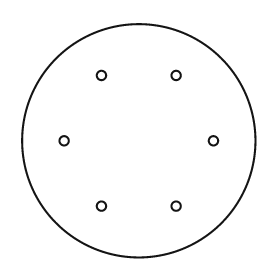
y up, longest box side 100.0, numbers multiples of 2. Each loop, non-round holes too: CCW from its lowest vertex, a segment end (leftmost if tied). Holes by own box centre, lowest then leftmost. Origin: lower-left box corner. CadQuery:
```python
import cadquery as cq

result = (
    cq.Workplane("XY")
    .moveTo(50.0, 50.0)
    .circle(50.0)
    .moveTo(34.0, 22.0)
    .circle(2.0)
    .moveTo(66.0, 22.0)
    .circle(2.0)
    .moveTo(18.0, 50.0)
    .circle(2.0)
    .moveTo(82.0, 50.0)
    .circle(2.0)
    .moveTo(34.0, 78.0)
    .circle(2.0)
    .moveTo(66.0, 78.0)
    .circle(2.0)
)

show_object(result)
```